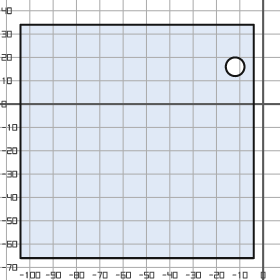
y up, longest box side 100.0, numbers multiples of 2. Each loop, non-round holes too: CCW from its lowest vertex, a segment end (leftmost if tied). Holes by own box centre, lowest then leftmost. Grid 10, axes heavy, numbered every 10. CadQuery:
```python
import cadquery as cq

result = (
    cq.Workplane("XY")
    .moveTo(-104.0, -66.0)
    .lineTo(-4.0, -66.0)
    .lineTo(-4.0, 34.0)
    .lineTo(-104.0, 34.0)
    .close()
    .moveTo(-12.0, 16.0)
    .circle(4.0)
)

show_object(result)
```